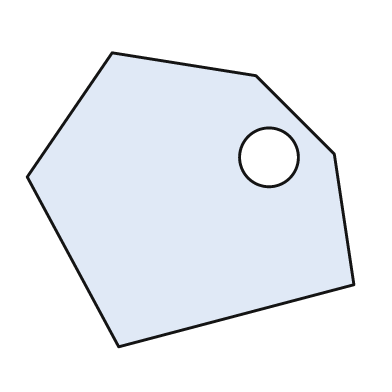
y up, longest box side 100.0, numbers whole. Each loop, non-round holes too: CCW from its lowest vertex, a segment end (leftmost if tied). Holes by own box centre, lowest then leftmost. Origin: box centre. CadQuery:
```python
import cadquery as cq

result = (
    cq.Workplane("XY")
    .moveTo(-22.0, -45.0)
    .lineTo(50.0, -26.0)
    .lineTo(44.0, 14.0)
    .lineTo(20.0, 38.0)
    .lineTo(-24.0, 45.0)
    .lineTo(-50.0, 7.0)
    .close()
    .moveTo(24.0, 13.0)
    .circle(9.0)
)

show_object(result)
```